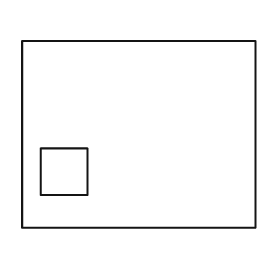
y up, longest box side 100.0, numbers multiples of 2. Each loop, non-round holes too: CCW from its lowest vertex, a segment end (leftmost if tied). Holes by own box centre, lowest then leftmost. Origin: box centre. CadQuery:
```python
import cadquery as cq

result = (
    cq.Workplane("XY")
    .moveTo(-50.0, -40.0)
    .lineTo(50.0, -40.0)
    .lineTo(50.0, 40.0)
    .lineTo(-50.0, 40.0)
    .close()
    .moveTo(-42.0, -26.0)
    .lineTo(-22.0, -26.0)
    .lineTo(-22.0, -6.0)
    .lineTo(-42.0, -6.0)
    .close()
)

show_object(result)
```